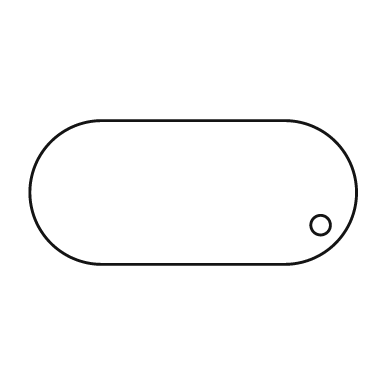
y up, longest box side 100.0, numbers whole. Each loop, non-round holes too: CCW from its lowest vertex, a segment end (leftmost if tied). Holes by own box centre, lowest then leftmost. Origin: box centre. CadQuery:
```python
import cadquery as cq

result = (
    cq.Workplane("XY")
    .moveTo(-28.0, -22.0)
    .lineTo(28.0, -22.0)
    .threePointArc((50.0, 0.0), (28.0, 22.0))
    .lineTo(-28.0, 22.0)
    .threePointArc((-50.0, 0.0), (-28.0, -22.0))
    .close()
    .moveTo(39.0, -10.0)
    .circle(3.0)
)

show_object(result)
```